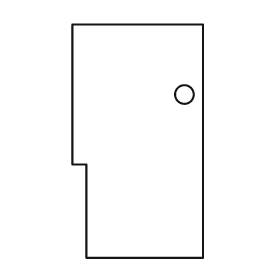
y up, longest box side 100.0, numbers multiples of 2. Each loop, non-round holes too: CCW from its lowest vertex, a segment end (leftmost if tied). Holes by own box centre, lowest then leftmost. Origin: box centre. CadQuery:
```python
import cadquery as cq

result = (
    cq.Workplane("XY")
    .moveTo(-22.0, -50.0)
    .lineTo(28.0, -50.0)
    .lineTo(28.0, 50.0)
    .lineTo(-28.0, 50.0)
    .lineTo(-28.0, -10.0)
    .lineTo(-22.0, -10.0)
    .close()
    .moveTo(20.0, 20.0)
    .circle(4.0)
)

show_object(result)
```